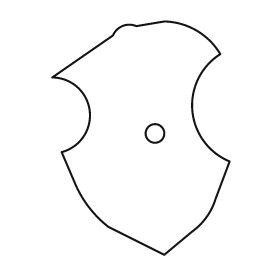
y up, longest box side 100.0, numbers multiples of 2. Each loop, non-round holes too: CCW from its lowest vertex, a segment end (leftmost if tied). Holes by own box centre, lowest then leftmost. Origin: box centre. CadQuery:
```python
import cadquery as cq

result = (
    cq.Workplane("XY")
    .moveTo(10.0, -50.0)
    .lineTo(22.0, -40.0)
    .threePointArc((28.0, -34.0), (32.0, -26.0))
    .lineTo(38.0, -10.0)
    .threePointArc((22.0, 12.0), (34.0, 36.0))
    .threePointArc((24.0, 46.0), (10.0, 50.0))
    .lineTo(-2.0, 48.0)
    .threePointArc((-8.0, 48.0), (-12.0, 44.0))
    .lineTo(-38.0, 26.0)
    .threePointArc((-22.0, 12.0), (-34.0, -6.0))
    .lineTo(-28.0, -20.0)
    .threePointArc((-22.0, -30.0), (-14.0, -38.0))
    .close()
    .moveTo(6.0, 2.0)
    .circle(4.0)
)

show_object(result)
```